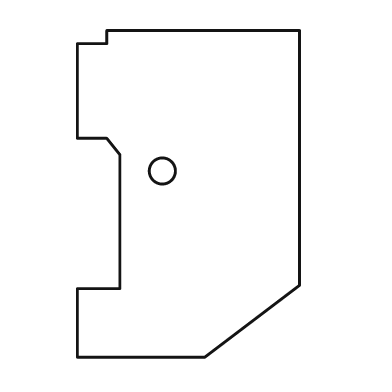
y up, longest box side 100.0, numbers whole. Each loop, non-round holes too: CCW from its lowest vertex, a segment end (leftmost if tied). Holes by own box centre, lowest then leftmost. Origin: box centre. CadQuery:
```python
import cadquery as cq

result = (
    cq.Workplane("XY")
    .moveTo(-34.0, -50.0)
    .lineTo(5.0, -50.0)
    .lineTo(34.0, -28.0)
    .lineTo(34.0, 50.0)
    .lineTo(-25.0, 50.0)
    .lineTo(-25.0, 46.0)
    .lineTo(-34.0, 46.0)
    .lineTo(-34.0, 17.0)
    .lineTo(-25.0, 17.0)
    .lineTo(-21.0, 12.0)
    .lineTo(-21.0, -29.0)
    .lineTo(-34.0, -29.0)
    .close()
    .moveTo(-8.0, 7.0)
    .circle(4.0)
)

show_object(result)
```